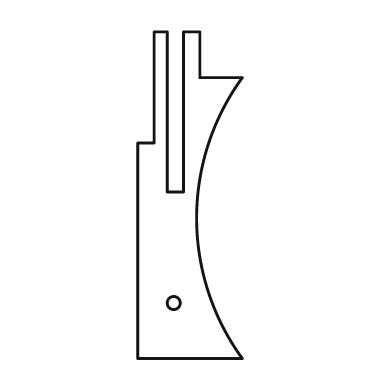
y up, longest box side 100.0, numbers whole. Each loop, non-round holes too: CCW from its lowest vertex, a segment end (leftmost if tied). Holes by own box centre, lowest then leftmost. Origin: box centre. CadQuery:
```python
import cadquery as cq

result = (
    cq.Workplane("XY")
    .moveTo(-16.0, -50.0)
    .lineTo(16.0, -50.0)
    .threePointArc((2.0, -7.0), (16.0, 36.0))
    .lineTo(3.0, 36.0)
    .lineTo(3.0, 50.0)
    .lineTo(-2.0, 50.0)
    .lineTo(-2.0, 1.0)
    .lineTo(-7.0, 1.0)
    .lineTo(-7.0, 50.0)
    .lineTo(-11.0, 50.0)
    .lineTo(-11.0, 16.0)
    .lineTo(-16.0, 16.0)
    .close()
    .moveTo(-5.0, -33.0)
    .circle(2.0)
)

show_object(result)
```